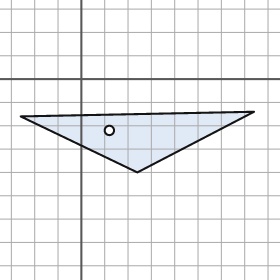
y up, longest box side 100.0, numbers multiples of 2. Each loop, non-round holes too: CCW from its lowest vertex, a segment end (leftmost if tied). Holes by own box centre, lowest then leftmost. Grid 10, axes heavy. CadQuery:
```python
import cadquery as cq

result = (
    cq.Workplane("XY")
    .moveTo(24.0, -40.0)
    .lineTo(74.0, -14.0)
    .lineTo(-26.0, -16.0)
    .close()
    .moveTo(12.0, -22.0)
    .circle(2.0)
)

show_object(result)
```